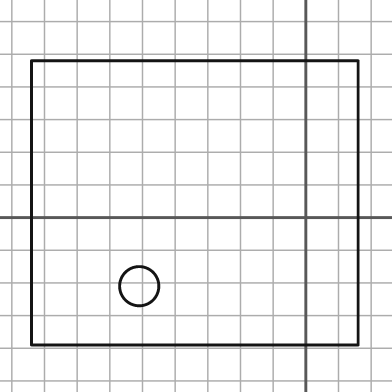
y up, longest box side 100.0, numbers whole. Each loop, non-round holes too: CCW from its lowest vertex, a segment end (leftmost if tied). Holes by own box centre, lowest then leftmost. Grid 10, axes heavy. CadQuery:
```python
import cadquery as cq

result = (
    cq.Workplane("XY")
    .moveTo(-84.0, -39.0)
    .lineTo(16.0, -39.0)
    .lineTo(16.0, 48.0)
    .lineTo(-84.0, 48.0)
    .close()
    .moveTo(-51.0, -21.0)
    .circle(6.0)
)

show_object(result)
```